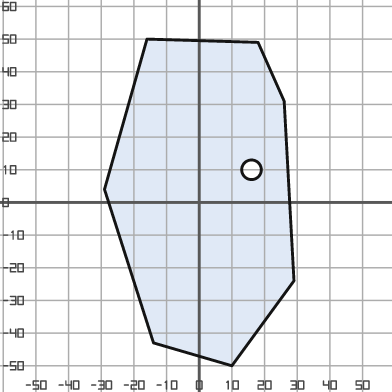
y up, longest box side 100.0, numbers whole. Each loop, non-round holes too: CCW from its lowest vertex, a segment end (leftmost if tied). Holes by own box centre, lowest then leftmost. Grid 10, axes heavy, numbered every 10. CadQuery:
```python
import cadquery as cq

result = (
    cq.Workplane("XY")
    .moveTo(10.0, -50.0)
    .lineTo(29.0, -24.0)
    .lineTo(26.0, 31.0)
    .lineTo(18.0, 49.0)
    .lineTo(-16.0, 50.0)
    .lineTo(-29.0, 4.0)
    .lineTo(-14.0, -43.0)
    .close()
    .moveTo(16.0, 10.0)
    .circle(3.0)
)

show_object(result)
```